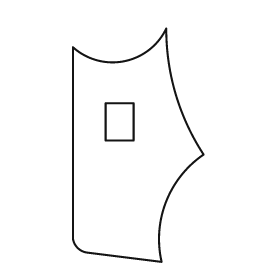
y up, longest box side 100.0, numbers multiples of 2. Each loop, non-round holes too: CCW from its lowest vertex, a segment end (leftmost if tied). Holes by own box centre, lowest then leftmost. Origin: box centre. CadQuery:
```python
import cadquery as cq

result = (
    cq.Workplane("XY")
    .moveTo(10.0, -50.0)
    .threePointArc((12.0, -24.0), (28.0, -4.0))
    .threePointArc((16.0, 22.0), (12.0, 50.0))
    .threePointArc((-6.0, 36.0), (-28.0, 42.0))
    .lineTo(-28.0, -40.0)
    .threePointArc((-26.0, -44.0), (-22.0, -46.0))
    .close()
    .moveTo(-14.0, 2.0)
    .lineTo(-2.0, 2.0)
    .lineTo(-2.0, 18.0)
    .lineTo(-14.0, 18.0)
    .close()
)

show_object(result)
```